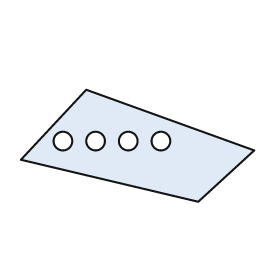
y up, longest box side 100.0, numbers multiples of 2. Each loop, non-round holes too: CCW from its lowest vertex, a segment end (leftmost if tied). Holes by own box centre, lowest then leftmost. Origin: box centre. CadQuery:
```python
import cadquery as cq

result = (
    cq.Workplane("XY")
    .moveTo(26.0, -24.0)
    .lineTo(50.0, -2.0)
    .lineTo(-22.0, 24.0)
    .lineTo(-50.0, -6.0)
    .close()
    .moveTo(-32.0, 2.0)
    .circle(4.0)
    .moveTo(-18.0, 2.0)
    .circle(4.0)
    .moveTo(-4.0, 2.0)
    .circle(4.0)
    .moveTo(10.0, 2.0)
    .circle(4.0)
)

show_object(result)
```